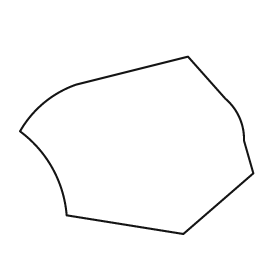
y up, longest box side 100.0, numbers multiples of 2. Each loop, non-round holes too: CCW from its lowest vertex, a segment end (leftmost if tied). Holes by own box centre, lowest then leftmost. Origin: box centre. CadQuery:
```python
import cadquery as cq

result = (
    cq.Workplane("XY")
    .moveTo(20.0, -38.0)
    .lineTo(50.0, -12.0)
    .lineTo(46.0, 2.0)
    .threePointArc((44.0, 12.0), (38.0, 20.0))
    .lineTo(22.0, 38.0)
    .lineTo(-26.0, 26.0)
    .threePointArc((-40.0, 18.0), (-50.0, 6.0))
    .threePointArc((-36.0, -10.0), (-30.0, -30.0))
    .close()
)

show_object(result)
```